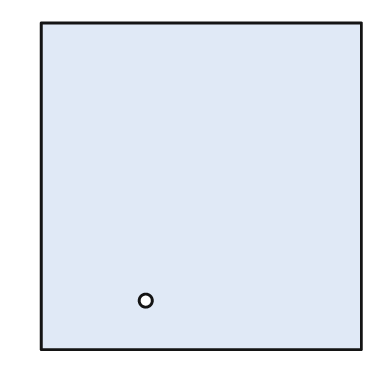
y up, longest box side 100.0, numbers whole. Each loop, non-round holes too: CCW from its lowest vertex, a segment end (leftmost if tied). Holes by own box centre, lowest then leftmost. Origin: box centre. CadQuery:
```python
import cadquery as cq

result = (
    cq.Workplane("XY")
    .moveTo(-49.0, -50.0)
    .lineTo(49.0, -50.0)
    .lineTo(49.0, 50.0)
    .lineTo(-49.0, 50.0)
    .close()
    .moveTo(-17.0, -35.0)
    .circle(2.0)
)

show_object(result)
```